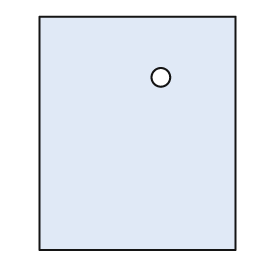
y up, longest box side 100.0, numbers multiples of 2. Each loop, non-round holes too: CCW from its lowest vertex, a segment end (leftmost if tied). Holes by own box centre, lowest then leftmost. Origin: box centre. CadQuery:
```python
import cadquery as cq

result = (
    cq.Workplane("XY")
    .moveTo(-42.0, -50.0)
    .lineTo(42.0, -50.0)
    .lineTo(42.0, 50.0)
    .lineTo(-42.0, 50.0)
    .close()
    .moveTo(10.0, 24.0)
    .circle(4.0)
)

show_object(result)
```